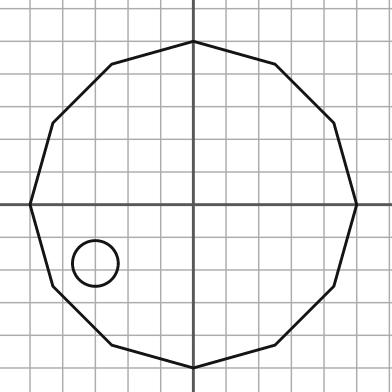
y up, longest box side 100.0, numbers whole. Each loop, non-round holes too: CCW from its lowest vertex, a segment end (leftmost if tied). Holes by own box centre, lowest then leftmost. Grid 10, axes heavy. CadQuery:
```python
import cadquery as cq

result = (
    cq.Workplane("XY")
    .moveTo(0.0, -50.0)
    .lineTo(25.0, -43.0)
    .lineTo(43.0, -25.0)
    .lineTo(50.0, 0.0)
    .lineTo(43.0, 25.0)
    .lineTo(25.0, 43.0)
    .lineTo(0.0, 50.0)
    .lineTo(-25.0, 43.0)
    .lineTo(-43.0, 25.0)
    .lineTo(-50.0, 0.0)
    .lineTo(-43.0, -25.0)
    .lineTo(-25.0, -43.0)
    .close()
    .moveTo(-30.0, -18.0)
    .circle(7.0)
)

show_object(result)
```